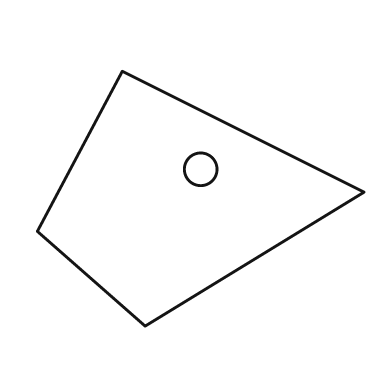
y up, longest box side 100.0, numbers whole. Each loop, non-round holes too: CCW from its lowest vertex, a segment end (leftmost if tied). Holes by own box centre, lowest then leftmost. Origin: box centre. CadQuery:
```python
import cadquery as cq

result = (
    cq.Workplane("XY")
    .moveTo(-17.0, -39.0)
    .lineTo(50.0, 2.0)
    .lineTo(-24.0, 39.0)
    .lineTo(-50.0, -10.0)
    .close()
    .moveTo(0.0, 9.0)
    .circle(5.0)
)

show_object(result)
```